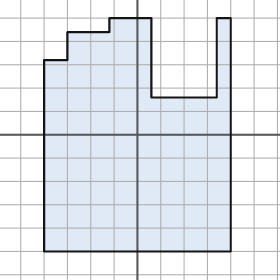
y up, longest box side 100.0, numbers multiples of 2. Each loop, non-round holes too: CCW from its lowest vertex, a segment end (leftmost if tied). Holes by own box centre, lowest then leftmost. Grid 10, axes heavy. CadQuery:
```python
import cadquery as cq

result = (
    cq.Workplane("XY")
    .moveTo(-40.0, -50.0)
    .lineTo(40.0, -50.0)
    .lineTo(40.0, 50.0)
    .lineTo(34.0, 50.0)
    .lineTo(34.0, 16.0)
    .lineTo(6.0, 16.0)
    .lineTo(6.0, 50.0)
    .lineTo(-12.0, 50.0)
    .lineTo(-12.0, 44.0)
    .lineTo(-30.0, 44.0)
    .lineTo(-30.0, 32.0)
    .lineTo(-40.0, 32.0)
    .close()
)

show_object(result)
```